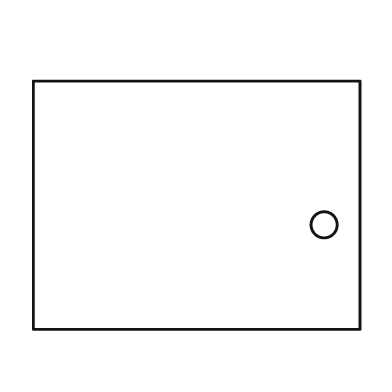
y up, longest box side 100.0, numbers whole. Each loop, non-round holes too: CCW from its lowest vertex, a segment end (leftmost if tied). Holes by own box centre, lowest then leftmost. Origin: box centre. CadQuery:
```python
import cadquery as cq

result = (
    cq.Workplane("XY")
    .moveTo(-50.0, -38.0)
    .lineTo(50.0, -38.0)
    .lineTo(50.0, 38.0)
    .lineTo(-50.0, 38.0)
    .close()
    .moveTo(39.0, -6.0)
    .circle(4.0)
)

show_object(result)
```